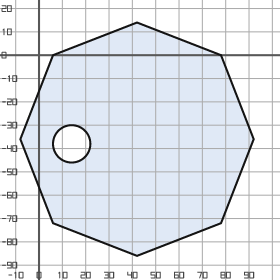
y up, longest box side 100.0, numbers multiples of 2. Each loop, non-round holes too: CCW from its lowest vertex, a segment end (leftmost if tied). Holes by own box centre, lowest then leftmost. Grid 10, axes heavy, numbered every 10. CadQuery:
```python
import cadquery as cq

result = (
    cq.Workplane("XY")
    .moveTo(42.0, -86.0)
    .lineTo(78.0, -72.0)
    .lineTo(92.0, -36.0)
    .lineTo(78.0, 0.0)
    .lineTo(42.0, 14.0)
    .lineTo(6.0, 0.0)
    .lineTo(-8.0, -36.0)
    .lineTo(6.0, -72.0)
    .close()
    .moveTo(14.0, -38.0)
    .circle(8.0)
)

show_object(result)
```